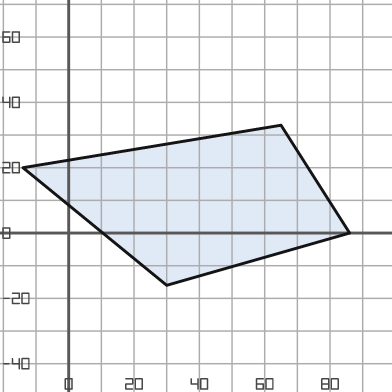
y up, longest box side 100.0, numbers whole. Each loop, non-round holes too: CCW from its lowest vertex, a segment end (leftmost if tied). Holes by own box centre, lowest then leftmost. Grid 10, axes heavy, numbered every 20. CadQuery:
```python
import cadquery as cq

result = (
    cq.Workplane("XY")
    .moveTo(30.0, -16.0)
    .lineTo(86.0, 0.0)
    .lineTo(65.0, 33.0)
    .lineTo(-14.0, 20.0)
    .close()
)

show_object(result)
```